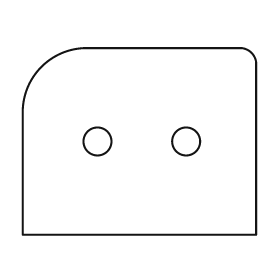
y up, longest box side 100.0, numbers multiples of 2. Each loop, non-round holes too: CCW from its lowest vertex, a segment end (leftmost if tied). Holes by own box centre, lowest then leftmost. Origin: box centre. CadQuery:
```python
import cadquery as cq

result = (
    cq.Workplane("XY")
    .moveTo(-50.0, -40.0)
    .lineTo(50.0, -40.0)
    .lineTo(50.0, 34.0)
    .threePointArc((48.0, 38.0), (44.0, 40.0))
    .lineTo(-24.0, 40.0)
    .threePointArc((-42.0, 32.0), (-50.0, 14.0))
    .close()
    .moveTo(-18.0, 0.0)
    .circle(6.0)
    .moveTo(20.0, 0.0)
    .circle(6.0)
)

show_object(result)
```